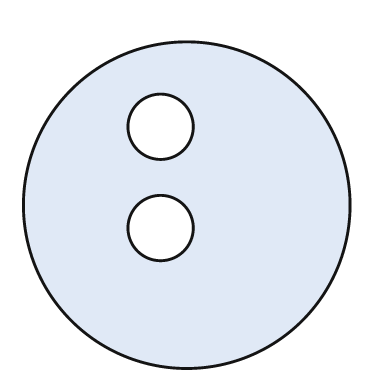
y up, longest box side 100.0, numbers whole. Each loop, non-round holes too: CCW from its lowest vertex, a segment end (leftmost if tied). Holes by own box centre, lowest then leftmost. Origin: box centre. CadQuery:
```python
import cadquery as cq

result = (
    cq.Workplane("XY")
    .moveTo(0.0, 0.0)
    .circle(50.0)
    .moveTo(-8.0, -7.0)
    .circle(10.0)
    .moveTo(-8.0, 24.0)
    .circle(10.0)
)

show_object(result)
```